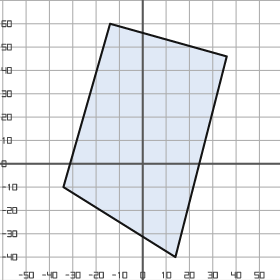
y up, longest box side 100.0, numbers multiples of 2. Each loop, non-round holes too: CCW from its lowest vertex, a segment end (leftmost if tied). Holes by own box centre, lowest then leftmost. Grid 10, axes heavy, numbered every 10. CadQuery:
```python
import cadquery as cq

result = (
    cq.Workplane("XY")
    .moveTo(14.0, -40.0)
    .lineTo(36.0, 46.0)
    .lineTo(-14.0, 60.0)
    .lineTo(-34.0, -10.0)
    .close()
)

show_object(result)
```